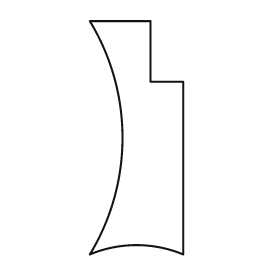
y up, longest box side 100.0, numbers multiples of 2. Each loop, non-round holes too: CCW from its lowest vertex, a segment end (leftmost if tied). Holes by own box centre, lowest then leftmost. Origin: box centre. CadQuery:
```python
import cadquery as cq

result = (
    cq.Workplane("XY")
    .moveTo(-20.0, -50.0)
    .threePointArc((0.0, -46.0), (20.0, -50.0))
    .lineTo(20.0, 24.0)
    .lineTo(6.0, 24.0)
    .lineTo(6.0, 50.0)
    .lineTo(-20.0, 50.0)
    .threePointArc((-6.0, 0.0), (-20.0, -50.0))
    .close()
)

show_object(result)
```